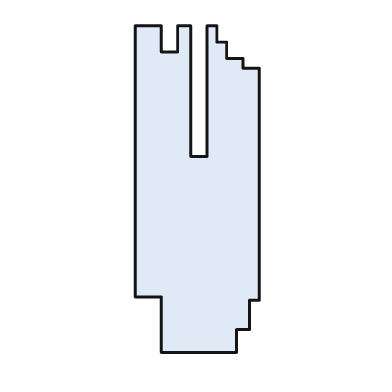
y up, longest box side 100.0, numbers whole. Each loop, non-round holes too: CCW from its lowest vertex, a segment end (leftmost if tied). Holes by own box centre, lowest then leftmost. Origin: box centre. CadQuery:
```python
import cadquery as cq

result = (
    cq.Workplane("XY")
    .moveTo(-11.0, -50.0)
    .lineTo(12.0, -50.0)
    .lineTo(12.0, -43.0)
    .lineTo(16.0, -43.0)
    .lineTo(16.0, -34.0)
    .lineTo(19.0, -34.0)
    .lineTo(19.0, 37.0)
    .lineTo(14.0, 37.0)
    .lineTo(14.0, 40.0)
    .lineTo(9.0, 40.0)
    .lineTo(9.0, 45.0)
    .lineTo(6.0, 45.0)
    .lineTo(6.0, 50.0)
    .lineTo(3.0, 50.0)
    .lineTo(3.0, 10.0)
    .lineTo(-2.0, 10.0)
    .lineTo(-2.0, 50.0)
    .lineTo(-6.0, 50.0)
    .lineTo(-6.0, 42.0)
    .lineTo(-11.0, 42.0)
    .lineTo(-11.0, 50.0)
    .lineTo(-19.0, 50.0)
    .lineTo(-19.0, -33.0)
    .lineTo(-11.0, -33.0)
    .close()
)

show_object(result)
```